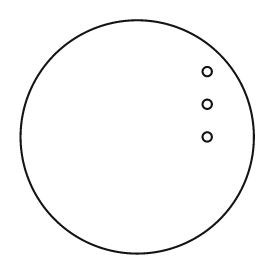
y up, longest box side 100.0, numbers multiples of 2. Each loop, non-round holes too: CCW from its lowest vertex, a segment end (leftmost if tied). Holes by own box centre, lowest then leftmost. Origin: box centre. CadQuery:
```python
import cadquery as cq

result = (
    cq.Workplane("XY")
    .moveTo(0.0, 0.0)
    .circle(50.0)
    .moveTo(30.0, 0.0)
    .circle(2.0)
    .moveTo(30.0, 14.0)
    .circle(2.0)
    .moveTo(30.0, 28.0)
    .circle(2.0)
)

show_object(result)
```